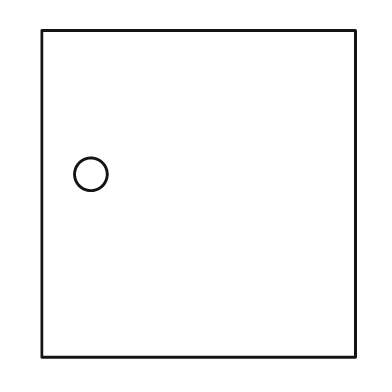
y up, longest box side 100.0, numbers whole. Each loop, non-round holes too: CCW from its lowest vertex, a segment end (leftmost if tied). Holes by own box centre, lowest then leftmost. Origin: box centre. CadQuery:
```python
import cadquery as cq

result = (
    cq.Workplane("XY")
    .moveTo(-48.0, -50.0)
    .lineTo(48.0, -50.0)
    .lineTo(48.0, 50.0)
    .lineTo(-48.0, 50.0)
    .close()
    .moveTo(-33.0, 6.0)
    .circle(5.0)
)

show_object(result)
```